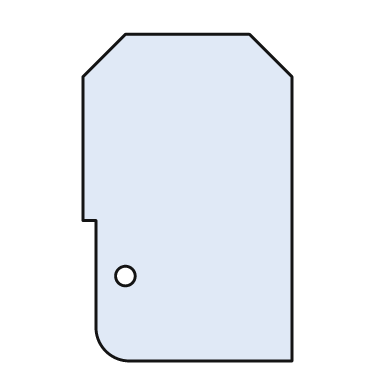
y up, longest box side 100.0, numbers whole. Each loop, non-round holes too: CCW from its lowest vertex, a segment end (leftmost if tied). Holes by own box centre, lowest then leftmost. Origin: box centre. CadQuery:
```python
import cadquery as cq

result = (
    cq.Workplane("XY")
    .moveTo(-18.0, -50.0)
    .lineTo(32.0, -50.0)
    .lineTo(32.0, 37.0)
    .lineTo(19.0, 50.0)
    .lineTo(-19.0, 50.0)
    .lineTo(-32.0, 37.0)
    .lineTo(-32.0, -7.0)
    .lineTo(-28.0, -7.0)
    .lineTo(-28.0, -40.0)
    .threePointArc((-25.0, -47.0), (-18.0, -50.0))
    .close()
    .moveTo(-19.0, -24.0)
    .circle(3.0)
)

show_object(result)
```